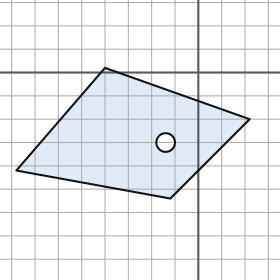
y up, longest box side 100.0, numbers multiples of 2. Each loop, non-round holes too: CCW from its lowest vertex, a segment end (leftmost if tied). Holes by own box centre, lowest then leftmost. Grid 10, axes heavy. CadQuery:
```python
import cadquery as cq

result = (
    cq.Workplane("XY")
    .moveTo(-12.0, -54.0)
    .lineTo(22.0, -20.0)
    .lineTo(-40.0, 2.0)
    .lineTo(-78.0, -42.0)
    .close()
    .moveTo(-14.0, -30.0)
    .circle(4.0)
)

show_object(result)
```